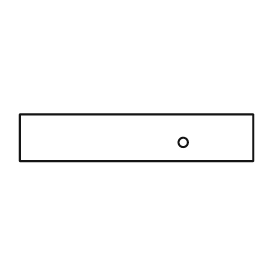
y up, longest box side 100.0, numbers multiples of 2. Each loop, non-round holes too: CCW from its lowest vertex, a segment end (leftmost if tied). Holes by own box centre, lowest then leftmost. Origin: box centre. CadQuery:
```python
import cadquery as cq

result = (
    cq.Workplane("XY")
    .moveTo(-50.0, -10.0)
    .lineTo(50.0, -10.0)
    .lineTo(50.0, 10.0)
    .lineTo(-50.0, 10.0)
    .close()
    .moveTo(20.0, -2.0)
    .circle(2.0)
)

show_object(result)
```